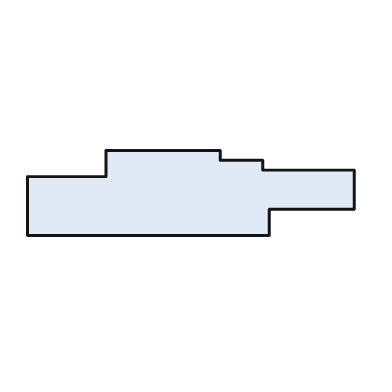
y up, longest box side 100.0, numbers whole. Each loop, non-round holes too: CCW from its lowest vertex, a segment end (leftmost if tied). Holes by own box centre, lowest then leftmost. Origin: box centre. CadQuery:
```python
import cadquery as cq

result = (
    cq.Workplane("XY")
    .moveTo(-50.0, -13.0)
    .lineTo(24.0, -13.0)
    .lineTo(24.0, -5.0)
    .lineTo(50.0, -5.0)
    .lineTo(50.0, 7.0)
    .lineTo(22.0, 7.0)
    .lineTo(22.0, 10.0)
    .lineTo(9.0, 10.0)
    .lineTo(9.0, 13.0)
    .lineTo(-26.0, 13.0)
    .lineTo(-26.0, 5.0)
    .lineTo(-50.0, 5.0)
    .close()
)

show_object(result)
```